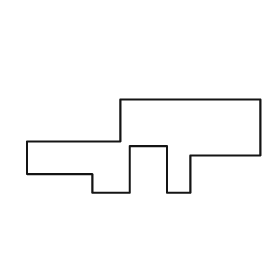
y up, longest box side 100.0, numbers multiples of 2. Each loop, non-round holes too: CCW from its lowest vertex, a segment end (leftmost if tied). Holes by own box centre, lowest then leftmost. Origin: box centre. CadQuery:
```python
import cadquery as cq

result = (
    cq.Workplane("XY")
    .moveTo(-22.0, -20.0)
    .lineTo(-6.0, -20.0)
    .lineTo(-6.0, 0.0)
    .lineTo(10.0, 0.0)
    .lineTo(10.0, -20.0)
    .lineTo(20.0, -20.0)
    .lineTo(20.0, -4.0)
    .lineTo(50.0, -4.0)
    .lineTo(50.0, 20.0)
    .lineTo(-10.0, 20.0)
    .lineTo(-10.0, 2.0)
    .lineTo(-50.0, 2.0)
    .lineTo(-50.0, -12.0)
    .lineTo(-22.0, -12.0)
    .close()
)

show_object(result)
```